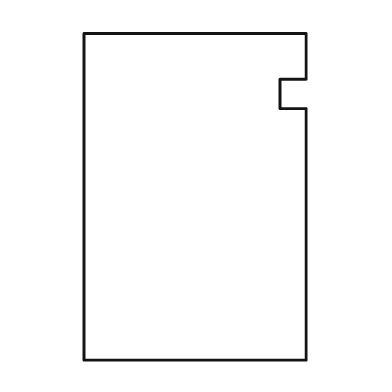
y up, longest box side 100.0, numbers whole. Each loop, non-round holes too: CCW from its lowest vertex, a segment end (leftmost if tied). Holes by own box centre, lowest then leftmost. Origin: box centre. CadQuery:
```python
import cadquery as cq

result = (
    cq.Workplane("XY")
    .moveTo(-34.0, -50.0)
    .lineTo(34.0, -50.0)
    .lineTo(34.0, 27.0)
    .lineTo(26.0, 27.0)
    .lineTo(26.0, 36.0)
    .lineTo(34.0, 36.0)
    .lineTo(34.0, 50.0)
    .lineTo(-34.0, 50.0)
    .close()
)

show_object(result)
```